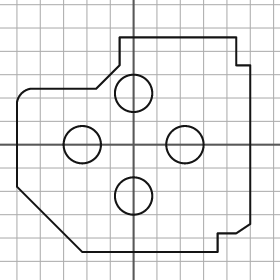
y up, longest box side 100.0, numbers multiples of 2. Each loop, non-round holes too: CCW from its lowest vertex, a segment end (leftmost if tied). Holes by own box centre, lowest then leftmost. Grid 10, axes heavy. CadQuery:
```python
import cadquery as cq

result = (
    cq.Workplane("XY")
    .moveTo(-22.0, -46.0)
    .lineTo(36.0, -46.0)
    .lineTo(36.0, -38.0)
    .lineTo(44.0, -38.0)
    .lineTo(50.0, -34.0)
    .lineTo(50.0, 34.0)
    .lineTo(44.0, 34.0)
    .lineTo(44.0, 46.0)
    .lineTo(-6.0, 46.0)
    .lineTo(-6.0, 34.0)
    .lineTo(-16.0, 24.0)
    .lineTo(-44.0, 24.0)
    .threePointArc((-48.0, 22.0), (-50.0, 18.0))
    .lineTo(-50.0, -18.0)
    .close()
    .moveTo(0.0, -22.0)
    .circle(8.0)
    .moveTo(-22.0, 0.0)
    .circle(8.0)
    .moveTo(22.0, 0.0)
    .circle(8.0)
    .moveTo(0.0, 22.0)
    .circle(8.0)
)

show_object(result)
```